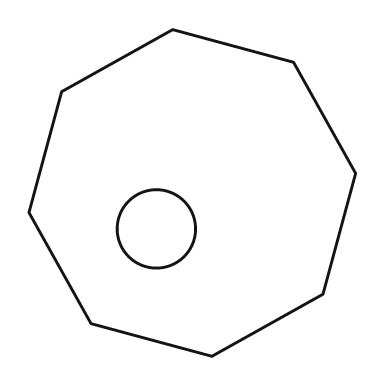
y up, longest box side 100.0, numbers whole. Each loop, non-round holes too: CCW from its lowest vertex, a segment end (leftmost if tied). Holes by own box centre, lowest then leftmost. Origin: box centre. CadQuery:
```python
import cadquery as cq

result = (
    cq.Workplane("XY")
    .moveTo(6.0, -50.0)
    .lineTo(40.0, -31.0)
    .lineTo(50.0, 6.0)
    .lineTo(31.0, 40.0)
    .lineTo(-6.0, 50.0)
    .lineTo(-40.0, 31.0)
    .lineTo(-50.0, -6.0)
    .lineTo(-31.0, -40.0)
    .close()
    .moveTo(-11.0, -11.0)
    .circle(12.0)
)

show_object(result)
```